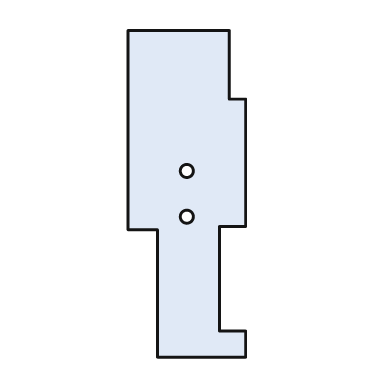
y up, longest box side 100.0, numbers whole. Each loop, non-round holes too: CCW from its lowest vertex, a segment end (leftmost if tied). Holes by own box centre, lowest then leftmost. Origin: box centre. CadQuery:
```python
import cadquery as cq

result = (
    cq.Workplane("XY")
    .moveTo(-9.0, -50.0)
    .lineTo(18.0, -50.0)
    .lineTo(18.0, -42.0)
    .lineTo(10.0, -42.0)
    .lineTo(10.0, -10.0)
    .lineTo(18.0, -10.0)
    .lineTo(18.0, 29.0)
    .lineTo(13.0, 29.0)
    .lineTo(13.0, 50.0)
    .lineTo(-18.0, 50.0)
    .lineTo(-18.0, -11.0)
    .lineTo(-9.0, -11.0)
    .close()
    .moveTo(0.0, -7.0)
    .circle(2.0)
    .moveTo(0.0, 7.0)
    .circle(2.0)
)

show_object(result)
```